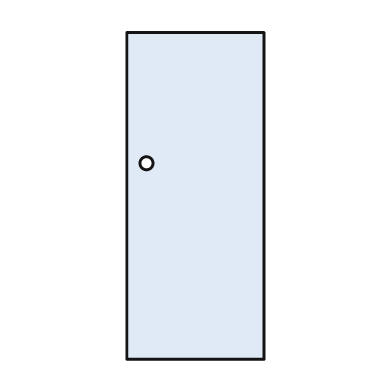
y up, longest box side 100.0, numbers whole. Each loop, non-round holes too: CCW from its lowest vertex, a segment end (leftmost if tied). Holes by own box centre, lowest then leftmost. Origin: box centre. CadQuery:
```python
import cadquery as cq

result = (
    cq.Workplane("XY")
    .moveTo(-21.0, -50.0)
    .lineTo(21.0, -50.0)
    .lineTo(21.0, 50.0)
    .lineTo(-21.0, 50.0)
    .close()
    .moveTo(-15.0, 10.0)
    .circle(2.0)
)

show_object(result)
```